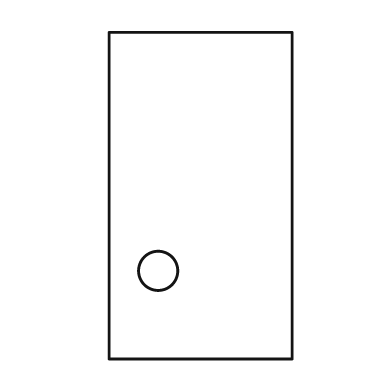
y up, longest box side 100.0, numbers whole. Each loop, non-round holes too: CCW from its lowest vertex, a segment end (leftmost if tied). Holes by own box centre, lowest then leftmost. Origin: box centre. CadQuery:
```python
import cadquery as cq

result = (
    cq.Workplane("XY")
    .moveTo(-28.0, -50.0)
    .lineTo(28.0, -50.0)
    .lineTo(28.0, 50.0)
    .lineTo(-28.0, 50.0)
    .close()
    .moveTo(-13.0, -23.0)
    .circle(6.0)
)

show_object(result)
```